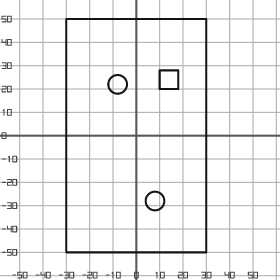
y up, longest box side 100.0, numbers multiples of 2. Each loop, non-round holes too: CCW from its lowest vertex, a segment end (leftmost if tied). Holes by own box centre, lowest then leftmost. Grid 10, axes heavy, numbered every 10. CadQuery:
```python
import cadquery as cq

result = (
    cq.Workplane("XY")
    .moveTo(-30.0, -50.0)
    .lineTo(30.0, -50.0)
    .lineTo(30.0, 50.0)
    .lineTo(-30.0, 50.0)
    .close()
    .moveTo(8.0, -28.0)
    .circle(4.0)
    .moveTo(-8.0, 22.0)
    .circle(4.0)
    .moveTo(10.0, 20.0)
    .lineTo(18.0, 20.0)
    .lineTo(18.0, 28.0)
    .lineTo(10.0, 28.0)
    .close()
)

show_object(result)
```